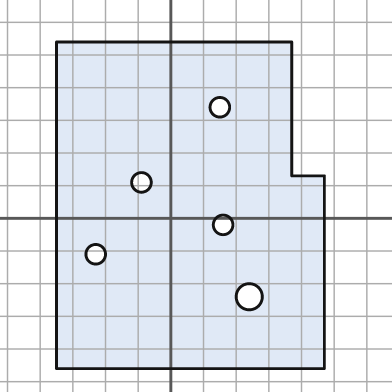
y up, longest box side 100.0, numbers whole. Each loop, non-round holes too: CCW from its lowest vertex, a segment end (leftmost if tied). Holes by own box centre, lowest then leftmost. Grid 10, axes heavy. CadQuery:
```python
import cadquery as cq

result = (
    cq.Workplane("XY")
    .moveTo(-35.0, -46.0)
    .lineTo(47.0, -46.0)
    .lineTo(47.0, 13.0)
    .lineTo(37.0, 13.0)
    .lineTo(37.0, 54.0)
    .lineTo(-35.0, 54.0)
    .close()
    .moveTo(24.0, -24.0)
    .circle(4.0)
    .moveTo(-23.0, -11.0)
    .circle(3.0)
    .moveTo(16.0, -2.0)
    .circle(3.0)
    .moveTo(-9.0, 11.0)
    .circle(3.0)
    .moveTo(15.0, 34.0)
    .circle(3.0)
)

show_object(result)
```